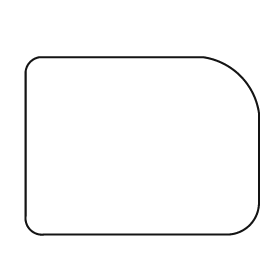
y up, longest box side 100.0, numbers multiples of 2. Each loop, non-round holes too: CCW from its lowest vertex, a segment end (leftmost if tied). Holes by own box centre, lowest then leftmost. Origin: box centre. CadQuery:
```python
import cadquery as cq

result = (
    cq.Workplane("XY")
    .moveTo(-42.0, -38.0)
    .lineTo(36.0, -38.0)
    .threePointArc((46.0, -34.0), (50.0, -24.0))
    .lineTo(50.0, 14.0)
    .threePointArc((42.0, 30.0), (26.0, 38.0))
    .lineTo(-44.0, 38.0)
    .threePointArc((-48.0, 36.0), (-50.0, 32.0))
    .lineTo(-50.0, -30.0)
    .threePointArc((-48.0, -36.0), (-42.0, -38.0))
    .close()
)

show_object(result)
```